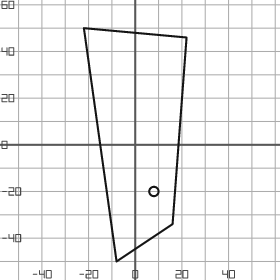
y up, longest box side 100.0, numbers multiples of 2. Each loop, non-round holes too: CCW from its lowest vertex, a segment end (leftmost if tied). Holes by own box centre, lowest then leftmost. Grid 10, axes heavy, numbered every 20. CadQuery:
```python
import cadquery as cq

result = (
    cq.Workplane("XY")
    .moveTo(-8.0, -50.0)
    .lineTo(16.0, -34.0)
    .lineTo(22.0, 46.0)
    .lineTo(-22.0, 50.0)
    .close()
    .moveTo(8.0, -20.0)
    .circle(2.0)
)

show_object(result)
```